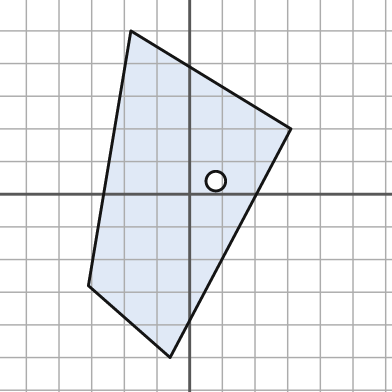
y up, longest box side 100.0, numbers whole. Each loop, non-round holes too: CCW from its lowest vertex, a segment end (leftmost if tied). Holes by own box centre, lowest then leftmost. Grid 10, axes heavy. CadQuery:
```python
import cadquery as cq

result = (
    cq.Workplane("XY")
    .moveTo(-6.0, -50.0)
    .lineTo(31.0, 20.0)
    .lineTo(-18.0, 50.0)
    .lineTo(-31.0, -28.0)
    .close()
    .moveTo(8.0, 4.0)
    .circle(3.0)
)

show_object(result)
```